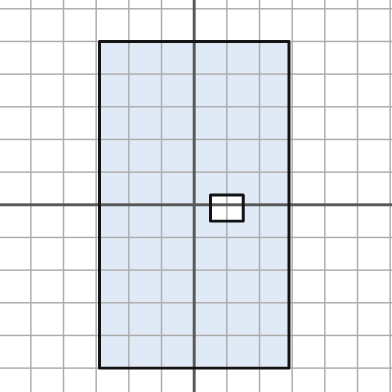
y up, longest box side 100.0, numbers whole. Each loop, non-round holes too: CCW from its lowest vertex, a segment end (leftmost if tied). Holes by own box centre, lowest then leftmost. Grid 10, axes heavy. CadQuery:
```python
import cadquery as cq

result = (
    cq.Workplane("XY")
    .moveTo(-29.0, -50.0)
    .lineTo(29.0, -50.0)
    .lineTo(29.0, 50.0)
    .lineTo(-29.0, 50.0)
    .close()
    .moveTo(5.0, -5.0)
    .lineTo(15.0, -5.0)
    .lineTo(15.0, 3.0)
    .lineTo(5.0, 3.0)
    .close()
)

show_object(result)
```